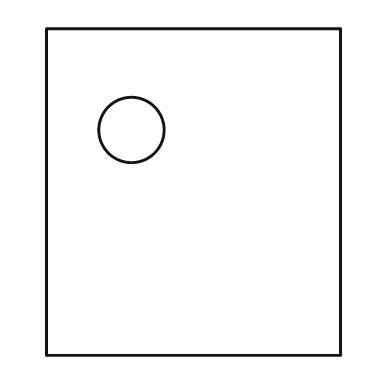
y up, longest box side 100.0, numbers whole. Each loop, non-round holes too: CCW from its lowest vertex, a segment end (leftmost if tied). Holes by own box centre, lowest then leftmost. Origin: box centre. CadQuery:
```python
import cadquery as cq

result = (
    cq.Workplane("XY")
    .moveTo(-45.0, -50.0)
    .lineTo(45.0, -50.0)
    .lineTo(45.0, 50.0)
    .lineTo(-45.0, 50.0)
    .close()
    .moveTo(-19.0, 19.0)
    .circle(10.0)
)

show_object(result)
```